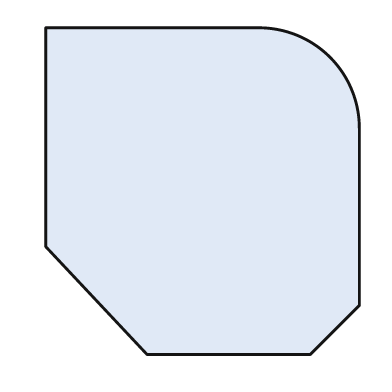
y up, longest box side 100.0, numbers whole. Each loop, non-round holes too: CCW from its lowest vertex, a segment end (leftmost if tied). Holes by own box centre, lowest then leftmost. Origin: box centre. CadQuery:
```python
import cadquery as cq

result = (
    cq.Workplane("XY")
    .moveTo(-17.0, -50.0)
    .lineTo(33.0, -50.0)
    .lineTo(48.0, -35.0)
    .lineTo(48.0, 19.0)
    .threePointArc((39.0, 41.0), (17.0, 50.0))
    .lineTo(-48.0, 50.0)
    .lineTo(-48.0, -17.0)
    .close()
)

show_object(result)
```